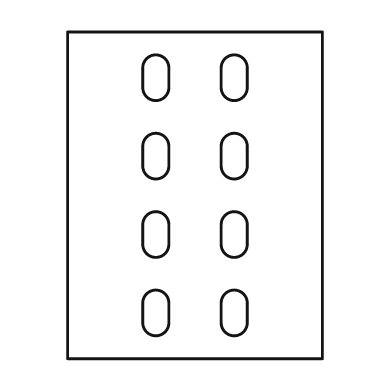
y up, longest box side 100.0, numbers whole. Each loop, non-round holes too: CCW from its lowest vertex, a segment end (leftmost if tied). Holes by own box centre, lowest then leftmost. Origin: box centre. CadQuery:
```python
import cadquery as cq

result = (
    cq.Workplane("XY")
    .moveTo(-39.0, -50.0)
    .lineTo(39.0, -50.0)
    .lineTo(39.0, 50.0)
    .lineTo(-39.0, 50.0)
    .close()
    .moveTo(-16.0, -39.0)
    .threePointArc((-12.0, -43.0), (-8.0, -39.0))
    .lineTo(-8.0, -33.0)
    .threePointArc((-12.0, -29.0), (-16.0, -33.0))
    .close()
    .moveTo(8.0, -39.0)
    .threePointArc((12.0, -43.0), (16.0, -39.0))
    .lineTo(16.0, -33.0)
    .threePointArc((12.0, -29.0), (8.0, -33.0))
    .close()
    .moveTo(-16.0, -15.0)
    .threePointArc((-12.0, -19.0), (-8.0, -15.0))
    .lineTo(-8.0, -9.0)
    .threePointArc((-12.0, -5.0), (-16.0, -9.0))
    .close()
    .moveTo(8.0, -15.0)
    .threePointArc((12.0, -19.0), (16.0, -15.0))
    .lineTo(16.0, -9.0)
    .threePointArc((12.0, -5.0), (8.0, -9.0))
    .close()
    .moveTo(-16.0, 9.0)
    .threePointArc((-12.0, 5.0), (-8.0, 9.0))
    .lineTo(-8.0, 15.0)
    .threePointArc((-12.0, 19.0), (-16.0, 15.0))
    .close()
    .moveTo(8.0, 9.0)
    .threePointArc((12.0, 5.0), (16.0, 9.0))
    .lineTo(16.0, 15.0)
    .threePointArc((12.0, 19.0), (8.0, 15.0))
    .close()
    .moveTo(-16.0, 33.0)
    .threePointArc((-12.0, 29.0), (-8.0, 33.0))
    .lineTo(-8.0, 39.0)
    .threePointArc((-12.0, 43.0), (-16.0, 39.0))
    .close()
    .moveTo(8.0, 33.0)
    .threePointArc((12.0, 29.0), (16.0, 33.0))
    .lineTo(16.0, 39.0)
    .threePointArc((12.0, 43.0), (8.0, 39.0))
    .close()
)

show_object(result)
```